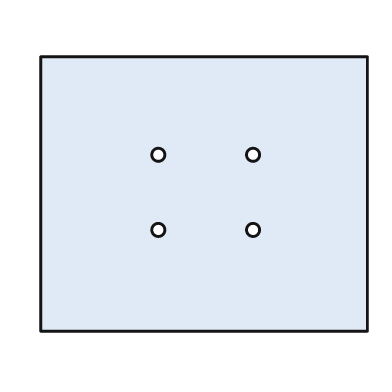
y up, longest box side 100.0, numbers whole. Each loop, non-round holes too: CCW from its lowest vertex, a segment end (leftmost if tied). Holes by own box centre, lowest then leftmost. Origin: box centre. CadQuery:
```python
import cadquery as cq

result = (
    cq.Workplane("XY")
    .moveTo(-50.0, -42.0)
    .lineTo(50.0, -42.0)
    .lineTo(50.0, 42.0)
    .lineTo(-50.0, 42.0)
    .close()
    .moveTo(-14.0, -11.0)
    .circle(2.0)
    .moveTo(15.0, -11.0)
    .circle(2.0)
    .moveTo(-14.0, 12.0)
    .circle(2.0)
    .moveTo(15.0, 12.0)
    .circle(2.0)
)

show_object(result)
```